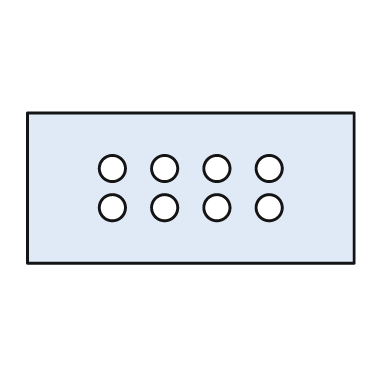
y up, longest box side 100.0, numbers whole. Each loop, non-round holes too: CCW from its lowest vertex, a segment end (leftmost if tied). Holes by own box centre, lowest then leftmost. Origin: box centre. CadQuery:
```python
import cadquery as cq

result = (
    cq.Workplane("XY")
    .moveTo(-50.0, -23.0)
    .lineTo(50.0, -23.0)
    .lineTo(50.0, 23.0)
    .lineTo(-50.0, 23.0)
    .close()
    .moveTo(-24.0, -6.0)
    .circle(4.0)
    .moveTo(-8.0, -6.0)
    .circle(4.0)
    .moveTo(8.0, -6.0)
    .circle(4.0)
    .moveTo(24.0, -6.0)
    .circle(4.0)
    .moveTo(-24.0, 6.0)
    .circle(4.0)
    .moveTo(-8.0, 6.0)
    .circle(4.0)
    .moveTo(8.0, 6.0)
    .circle(4.0)
    .moveTo(24.0, 6.0)
    .circle(4.0)
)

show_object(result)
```